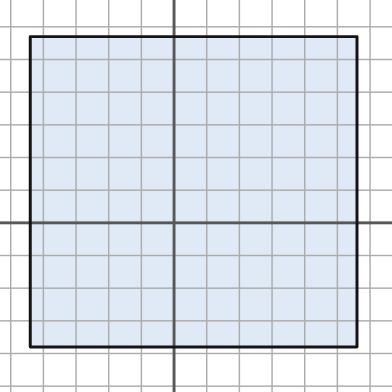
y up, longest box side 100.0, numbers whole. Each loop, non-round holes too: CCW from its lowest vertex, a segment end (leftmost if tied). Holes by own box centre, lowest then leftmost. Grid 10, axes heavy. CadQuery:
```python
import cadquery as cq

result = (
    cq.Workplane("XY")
    .moveTo(-44.0, -38.0)
    .lineTo(56.0, -38.0)
    .lineTo(56.0, 57.0)
    .lineTo(-44.0, 57.0)
    .close()
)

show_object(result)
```